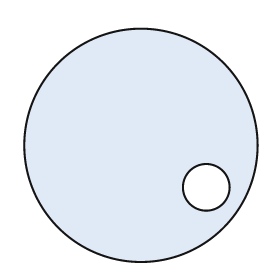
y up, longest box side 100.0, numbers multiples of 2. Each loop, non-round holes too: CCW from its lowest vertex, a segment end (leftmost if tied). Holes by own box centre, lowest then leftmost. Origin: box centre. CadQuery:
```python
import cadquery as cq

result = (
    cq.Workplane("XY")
    .moveTo(0.0, 0.0)
    .circle(50.0)
    .moveTo(28.0, -18.0)
    .circle(10.0)
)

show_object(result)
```